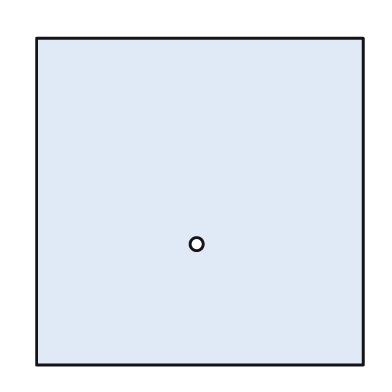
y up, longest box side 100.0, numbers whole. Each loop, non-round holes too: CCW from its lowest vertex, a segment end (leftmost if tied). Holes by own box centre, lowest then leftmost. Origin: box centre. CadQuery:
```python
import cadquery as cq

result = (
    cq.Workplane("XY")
    .moveTo(-50.0, -50.0)
    .lineTo(50.0, -50.0)
    .lineTo(50.0, 50.0)
    .lineTo(-50.0, 50.0)
    .close()
    .moveTo(-1.0, -13.0)
    .circle(2.0)
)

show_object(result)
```